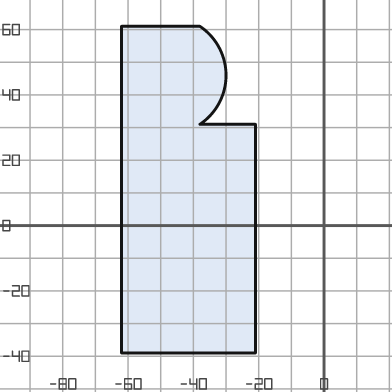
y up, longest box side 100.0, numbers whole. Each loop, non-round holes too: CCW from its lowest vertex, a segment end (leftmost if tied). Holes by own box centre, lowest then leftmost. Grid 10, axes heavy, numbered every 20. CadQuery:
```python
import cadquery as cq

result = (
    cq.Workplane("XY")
    .moveTo(-62.0, -39.0)
    .lineTo(-21.0, -39.0)
    .lineTo(-21.0, 31.0)
    .lineTo(-38.0, 31.0)
    .threePointArc((-30.0, 46.0), (-38.0, 61.0))
    .lineTo(-62.0, 61.0)
    .close()
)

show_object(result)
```